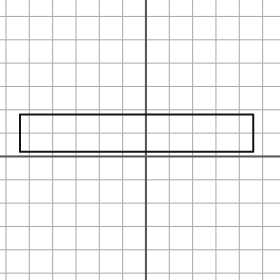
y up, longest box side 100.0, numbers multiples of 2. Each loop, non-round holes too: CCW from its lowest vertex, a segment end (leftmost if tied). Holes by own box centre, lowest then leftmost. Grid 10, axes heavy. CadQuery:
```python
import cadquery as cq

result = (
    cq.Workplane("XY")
    .moveTo(-54.0, 2.0)
    .lineTo(46.0, 2.0)
    .lineTo(46.0, 18.0)
    .lineTo(-54.0, 18.0)
    .close()
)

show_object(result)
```